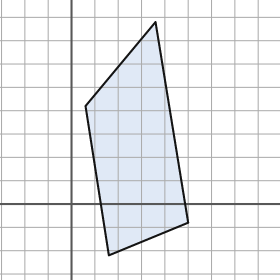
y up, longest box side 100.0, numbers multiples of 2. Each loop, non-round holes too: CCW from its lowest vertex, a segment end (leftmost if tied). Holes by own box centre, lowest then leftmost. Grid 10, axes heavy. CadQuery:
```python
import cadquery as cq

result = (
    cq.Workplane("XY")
    .moveTo(16.0, -22.0)
    .lineTo(50.0, -8.0)
    .lineTo(36.0, 78.0)
    .lineTo(6.0, 42.0)
    .close()
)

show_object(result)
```